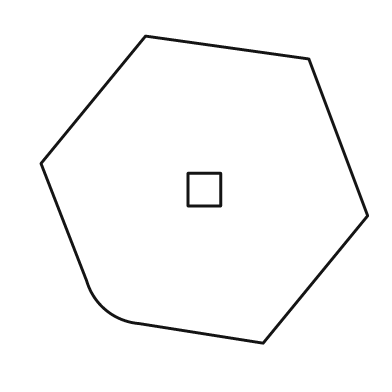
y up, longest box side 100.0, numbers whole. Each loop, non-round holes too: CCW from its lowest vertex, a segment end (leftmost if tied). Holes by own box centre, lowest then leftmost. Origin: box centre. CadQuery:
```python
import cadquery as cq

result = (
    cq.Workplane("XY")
    .moveTo(18.0, -47.0)
    .lineTo(50.0, -8.0)
    .lineTo(32.0, 40.0)
    .lineTo(-18.0, 47.0)
    .lineTo(-50.0, 8.0)
    .lineTo(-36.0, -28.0)
    .threePointArc((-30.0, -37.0), (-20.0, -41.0))
    .close()
    .moveTo(-5.0, -5.0)
    .lineTo(5.0, -5.0)
    .lineTo(5.0, 5.0)
    .lineTo(-5.0, 5.0)
    .close()
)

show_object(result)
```